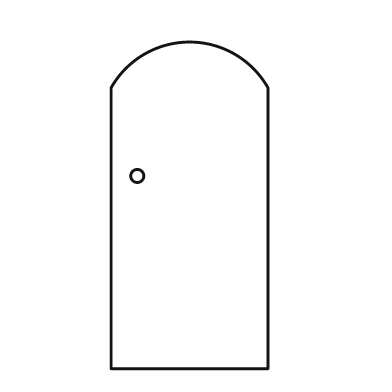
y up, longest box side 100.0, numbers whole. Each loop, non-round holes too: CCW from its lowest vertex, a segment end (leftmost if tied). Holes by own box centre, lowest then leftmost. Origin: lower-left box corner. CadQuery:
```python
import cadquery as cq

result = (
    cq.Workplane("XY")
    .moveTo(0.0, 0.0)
    .lineTo(48.0, 0.0)
    .lineTo(48.0, 86.0)
    .threePointArc((24.0, 100.0), (0.0, 86.0))
    .close()
    .moveTo(8.0, 59.0)
    .circle(2.0)
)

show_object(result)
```